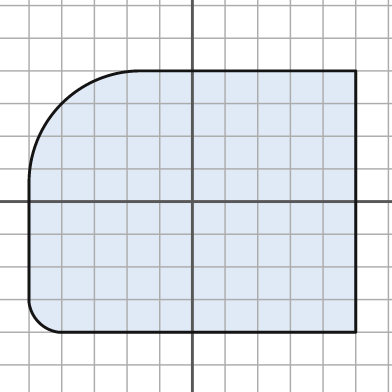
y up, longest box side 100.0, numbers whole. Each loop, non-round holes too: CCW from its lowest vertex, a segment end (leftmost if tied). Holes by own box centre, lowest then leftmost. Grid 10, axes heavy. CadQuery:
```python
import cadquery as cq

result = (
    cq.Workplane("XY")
    .moveTo(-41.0, -40.0)
    .lineTo(50.0, -40.0)
    .lineTo(50.0, 40.0)
    .lineTo(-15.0, 40.0)
    .threePointArc((-40.0, 30.0), (-50.0, 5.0))
    .lineTo(-50.0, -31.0)
    .threePointArc((-47.0, -37.0), (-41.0, -40.0))
    .close()
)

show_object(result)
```